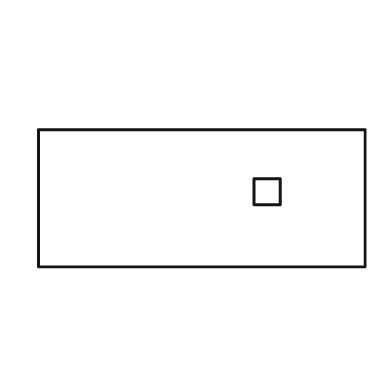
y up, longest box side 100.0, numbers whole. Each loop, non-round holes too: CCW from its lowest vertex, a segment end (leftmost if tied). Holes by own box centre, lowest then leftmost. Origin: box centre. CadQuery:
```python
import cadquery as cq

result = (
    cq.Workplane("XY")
    .moveTo(-50.0, -21.0)
    .lineTo(50.0, -21.0)
    .lineTo(50.0, 21.0)
    .lineTo(-50.0, 21.0)
    .close()
    .moveTo(16.0, -2.0)
    .lineTo(24.0, -2.0)
    .lineTo(24.0, 6.0)
    .lineTo(16.0, 6.0)
    .close()
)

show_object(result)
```